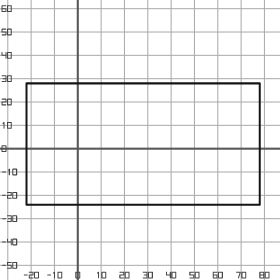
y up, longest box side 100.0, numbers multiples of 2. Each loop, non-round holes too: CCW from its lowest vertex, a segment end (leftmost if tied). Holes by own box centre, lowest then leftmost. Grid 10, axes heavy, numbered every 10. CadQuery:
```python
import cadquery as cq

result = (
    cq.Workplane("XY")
    .moveTo(-22.0, -24.0)
    .lineTo(78.0, -24.0)
    .lineTo(78.0, 28.0)
    .lineTo(-22.0, 28.0)
    .close()
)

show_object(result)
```